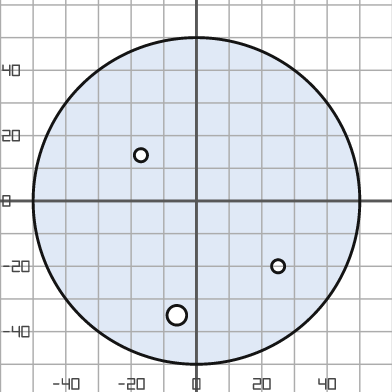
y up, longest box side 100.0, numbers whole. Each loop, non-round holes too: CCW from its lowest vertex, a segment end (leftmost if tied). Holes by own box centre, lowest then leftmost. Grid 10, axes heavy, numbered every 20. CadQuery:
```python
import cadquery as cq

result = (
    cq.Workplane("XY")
    .moveTo(0.0, 0.0)
    .circle(50.0)
    .moveTo(-6.0, -35.0)
    .circle(3.0)
    .moveTo(25.0, -20.0)
    .circle(2.0)
    .moveTo(-17.0, 14.0)
    .circle(2.0)
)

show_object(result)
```